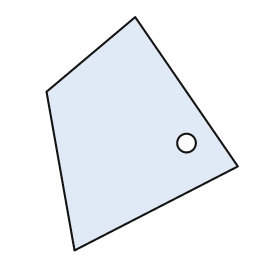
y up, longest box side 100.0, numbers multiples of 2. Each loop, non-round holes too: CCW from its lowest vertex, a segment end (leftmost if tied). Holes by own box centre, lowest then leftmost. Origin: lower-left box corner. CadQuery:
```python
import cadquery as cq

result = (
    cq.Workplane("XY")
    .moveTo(12.0, 0.0)
    .lineTo(82.0, 36.0)
    .lineTo(38.0, 100.0)
    .lineTo(0.0, 68.0)
    .close()
    .moveTo(60.0, 46.0)
    .circle(4.0)
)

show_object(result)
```